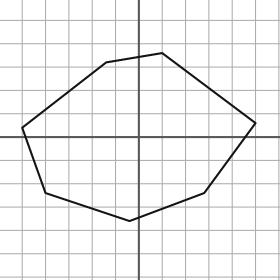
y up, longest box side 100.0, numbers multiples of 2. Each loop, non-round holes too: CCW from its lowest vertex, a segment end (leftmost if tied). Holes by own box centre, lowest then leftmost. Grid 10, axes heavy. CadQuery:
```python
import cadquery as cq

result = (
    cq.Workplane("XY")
    .moveTo(-4.0, -36.0)
    .lineTo(28.0, -24.0)
    .lineTo(50.0, 6.0)
    .lineTo(10.0, 36.0)
    .lineTo(-14.0, 32.0)
    .lineTo(-50.0, 4.0)
    .lineTo(-40.0, -24.0)
    .close()
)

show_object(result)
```